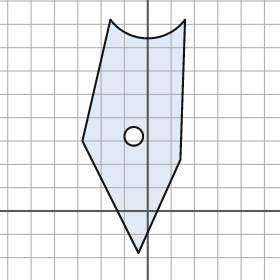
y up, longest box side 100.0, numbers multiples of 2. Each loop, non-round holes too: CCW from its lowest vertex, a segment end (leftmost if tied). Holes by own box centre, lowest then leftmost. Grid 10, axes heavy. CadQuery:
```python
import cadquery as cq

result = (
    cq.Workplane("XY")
    .moveTo(-4.0, -18.0)
    .lineTo(14.0, 22.0)
    .lineTo(16.0, 82.0)
    .threePointArc((0.0, 74.0), (-16.0, 82.0))
    .lineTo(-28.0, 30.0)
    .close()
    .moveTo(-6.0, 32.0)
    .circle(4.0)
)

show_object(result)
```